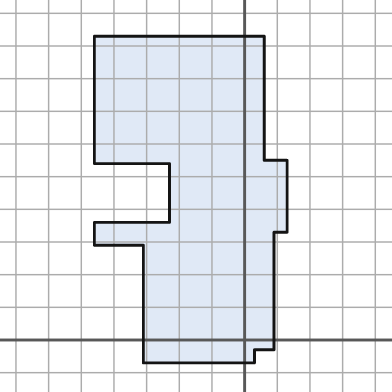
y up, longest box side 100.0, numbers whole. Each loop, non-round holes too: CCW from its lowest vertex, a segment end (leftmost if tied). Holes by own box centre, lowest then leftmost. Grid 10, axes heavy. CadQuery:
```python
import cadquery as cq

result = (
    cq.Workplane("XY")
    .moveTo(-31.0, -7.0)
    .lineTo(3.0, -7.0)
    .lineTo(3.0, -3.0)
    .lineTo(9.0, -3.0)
    .lineTo(9.0, 33.0)
    .lineTo(13.0, 33.0)
    .lineTo(13.0, 55.0)
    .lineTo(6.0, 55.0)
    .lineTo(6.0, 93.0)
    .lineTo(-46.0, 93.0)
    .lineTo(-46.0, 54.0)
    .lineTo(-23.0, 54.0)
    .lineTo(-23.0, 36.0)
    .lineTo(-46.0, 36.0)
    .lineTo(-46.0, 29.0)
    .lineTo(-31.0, 29.0)
    .close()
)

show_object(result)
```